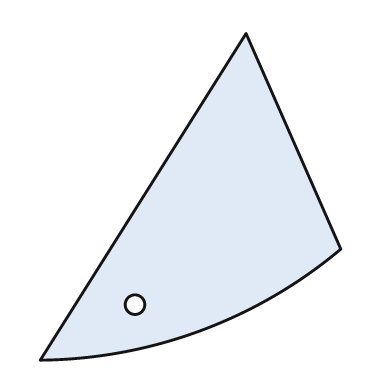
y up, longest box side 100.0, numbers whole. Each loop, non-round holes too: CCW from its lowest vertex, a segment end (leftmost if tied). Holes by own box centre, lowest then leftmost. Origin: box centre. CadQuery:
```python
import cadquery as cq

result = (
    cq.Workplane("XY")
    .moveTo(-46.0, -50.0)
    .threePointArc((3.0, -41.0), (46.0, -16.0))
    .lineTo(17.0, 50.0)
    .close()
    .moveTo(-17.0, -33.0)
    .circle(3.0)
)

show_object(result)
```